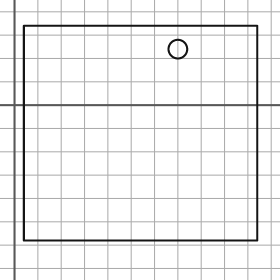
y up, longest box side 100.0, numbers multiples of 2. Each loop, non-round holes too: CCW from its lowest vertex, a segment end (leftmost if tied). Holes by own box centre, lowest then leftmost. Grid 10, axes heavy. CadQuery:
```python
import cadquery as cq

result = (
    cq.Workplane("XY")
    .moveTo(4.0, -58.0)
    .lineTo(104.0, -58.0)
    .lineTo(104.0, 34.0)
    .lineTo(4.0, 34.0)
    .close()
    .moveTo(70.0, 24.0)
    .circle(4.0)
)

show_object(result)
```